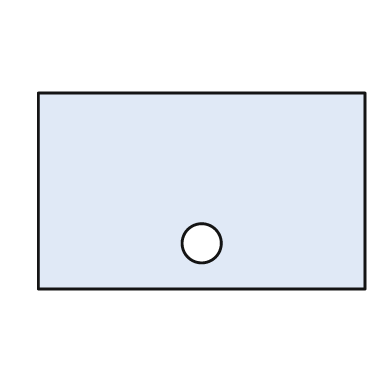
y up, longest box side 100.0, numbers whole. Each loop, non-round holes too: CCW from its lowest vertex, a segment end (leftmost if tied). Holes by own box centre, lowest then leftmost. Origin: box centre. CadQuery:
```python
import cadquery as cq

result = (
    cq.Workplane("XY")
    .moveTo(-50.0, -30.0)
    .lineTo(50.0, -30.0)
    .lineTo(50.0, 30.0)
    .lineTo(-50.0, 30.0)
    .close()
    .moveTo(0.0, -16.0)
    .circle(6.0)
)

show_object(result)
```